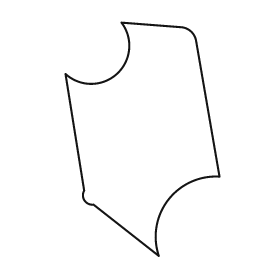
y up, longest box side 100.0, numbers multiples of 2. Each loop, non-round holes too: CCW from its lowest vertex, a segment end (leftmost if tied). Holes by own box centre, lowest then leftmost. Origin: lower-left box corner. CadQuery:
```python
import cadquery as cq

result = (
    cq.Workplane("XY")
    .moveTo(40.0, 0.0)
    .threePointArc((44.0, 24.0), (66.0, 34.0))
    .lineTo(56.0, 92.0)
    .threePointArc((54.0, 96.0), (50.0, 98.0))
    .lineTo(24.0, 100.0)
    .threePointArc((22.0, 78.0), (0.0, 78.0))
    .lineTo(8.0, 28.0)
    .threePointArc((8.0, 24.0), (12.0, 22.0))
    .close()
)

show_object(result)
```